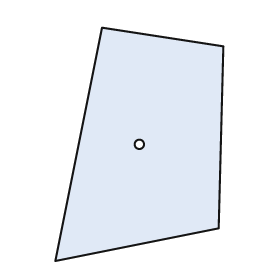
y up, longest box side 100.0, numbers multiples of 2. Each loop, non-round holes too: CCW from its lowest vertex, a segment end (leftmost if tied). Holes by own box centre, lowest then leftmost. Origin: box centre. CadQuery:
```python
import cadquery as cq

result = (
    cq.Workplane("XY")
    .moveTo(-36.0, -50.0)
    .lineTo(34.0, -36.0)
    .lineTo(36.0, 42.0)
    .lineTo(-16.0, 50.0)
    .close()
    .moveTo(0.0, 0.0)
    .circle(2.0)
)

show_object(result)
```